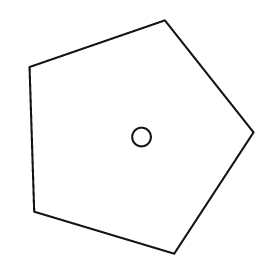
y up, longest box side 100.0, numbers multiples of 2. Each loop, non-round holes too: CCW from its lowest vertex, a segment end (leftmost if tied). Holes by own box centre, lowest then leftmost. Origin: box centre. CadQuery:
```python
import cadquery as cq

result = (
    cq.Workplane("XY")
    .moveTo(14.0, -50.0)
    .lineTo(48.0, 2.0)
    .lineTo(10.0, 50.0)
    .lineTo(-48.0, 30.0)
    .lineTo(-46.0, -32.0)
    .close()
    .moveTo(0.0, 0.0)
    .circle(4.0)
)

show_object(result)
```